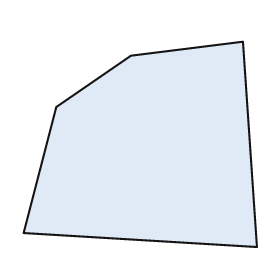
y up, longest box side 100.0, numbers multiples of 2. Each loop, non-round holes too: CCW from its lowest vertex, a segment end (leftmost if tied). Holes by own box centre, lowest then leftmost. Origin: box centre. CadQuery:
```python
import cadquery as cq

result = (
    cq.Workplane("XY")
    .moveTo(50.0, -44.0)
    .lineTo(44.0, 44.0)
    .lineTo(-4.0, 38.0)
    .lineTo(-36.0, 16.0)
    .lineTo(-50.0, -38.0)
    .close()
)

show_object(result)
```